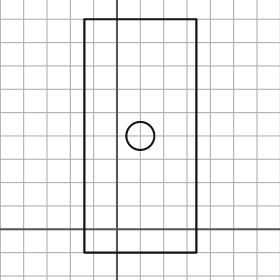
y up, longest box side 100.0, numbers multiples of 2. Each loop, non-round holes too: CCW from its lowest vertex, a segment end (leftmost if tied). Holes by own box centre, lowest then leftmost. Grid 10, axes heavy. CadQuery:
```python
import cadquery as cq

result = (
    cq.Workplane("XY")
    .moveTo(-14.0, -10.0)
    .lineTo(34.0, -10.0)
    .lineTo(34.0, 90.0)
    .lineTo(-14.0, 90.0)
    .close()
    .moveTo(10.0, 40.0)
    .circle(6.0)
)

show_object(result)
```